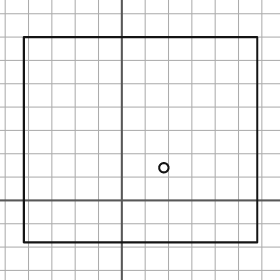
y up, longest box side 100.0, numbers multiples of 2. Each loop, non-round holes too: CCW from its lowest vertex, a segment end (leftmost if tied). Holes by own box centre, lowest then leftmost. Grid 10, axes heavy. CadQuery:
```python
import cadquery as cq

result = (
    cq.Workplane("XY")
    .moveTo(-42.0, -18.0)
    .lineTo(58.0, -18.0)
    .lineTo(58.0, 70.0)
    .lineTo(-42.0, 70.0)
    .close()
    .moveTo(18.0, 14.0)
    .circle(2.0)
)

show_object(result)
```